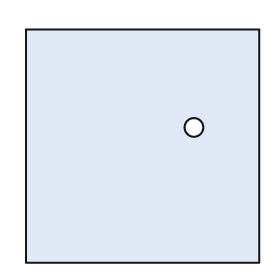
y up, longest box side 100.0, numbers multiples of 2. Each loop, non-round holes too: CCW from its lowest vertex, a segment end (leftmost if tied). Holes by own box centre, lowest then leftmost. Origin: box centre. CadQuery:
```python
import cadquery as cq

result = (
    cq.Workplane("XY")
    .moveTo(-50.0, -50.0)
    .lineTo(50.0, -50.0)
    .lineTo(50.0, 50.0)
    .lineTo(-50.0, 50.0)
    .close()
    .moveTo(22.0, 8.0)
    .circle(4.0)
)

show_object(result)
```